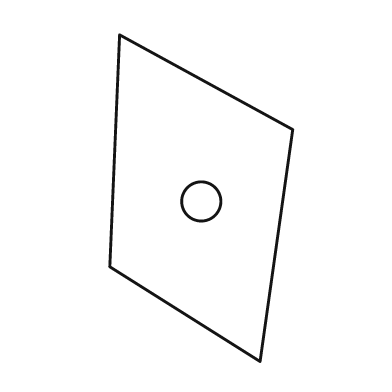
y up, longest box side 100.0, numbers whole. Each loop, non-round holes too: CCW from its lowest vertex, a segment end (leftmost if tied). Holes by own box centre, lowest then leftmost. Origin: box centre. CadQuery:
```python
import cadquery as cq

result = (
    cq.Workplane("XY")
    .moveTo(18.0, -50.0)
    .lineTo(28.0, 21.0)
    .lineTo(-25.0, 50.0)
    .lineTo(-28.0, -21.0)
    .close()
    .moveTo(0.0, -1.0)
    .circle(6.0)
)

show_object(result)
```